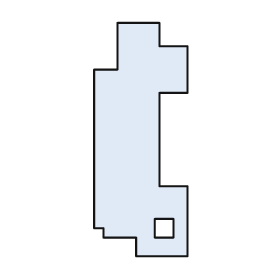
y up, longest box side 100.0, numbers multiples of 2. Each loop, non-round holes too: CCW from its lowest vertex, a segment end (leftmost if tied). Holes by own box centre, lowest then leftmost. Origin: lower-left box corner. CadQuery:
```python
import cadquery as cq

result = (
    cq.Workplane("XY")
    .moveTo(18.0, 0.0)
    .lineTo(40.0, 0.0)
    .lineTo(40.0, 30.0)
    .lineTo(28.0, 30.0)
    .lineTo(28.0, 70.0)
    .lineTo(40.0, 70.0)
    .lineTo(40.0, 90.0)
    .lineTo(28.0, 90.0)
    .lineTo(28.0, 100.0)
    .lineTo(10.0, 100.0)
    .lineTo(10.0, 80.0)
    .lineTo(0.0, 80.0)
    .lineTo(0.0, 12.0)
    .lineTo(4.0, 12.0)
    .lineTo(4.0, 8.0)
    .lineTo(18.0, 8.0)
    .close()
    .moveTo(26.0, 8.0)
    .lineTo(34.0, 8.0)
    .lineTo(34.0, 16.0)
    .lineTo(26.0, 16.0)
    .close()
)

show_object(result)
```